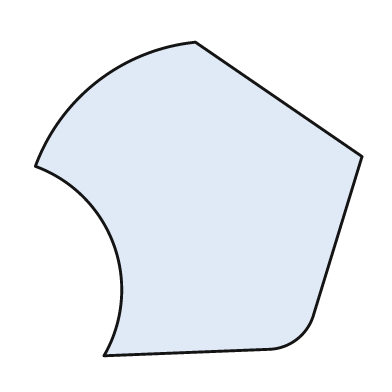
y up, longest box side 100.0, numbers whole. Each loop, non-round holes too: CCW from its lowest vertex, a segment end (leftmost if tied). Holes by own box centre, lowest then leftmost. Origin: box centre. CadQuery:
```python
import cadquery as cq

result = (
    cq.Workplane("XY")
    .moveTo(-29.0, -48.0)
    .lineTo(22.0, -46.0)
    .threePointArc((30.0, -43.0), (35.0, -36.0))
    .lineTo(50.0, 13.0)
    .lineTo(-1.0, 48.0)
    .threePointArc((-31.0, 36.0), (-50.0, 10.0))
    .threePointArc((-26.0, -14.0), (-29.0, -48.0))
    .close()
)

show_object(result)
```